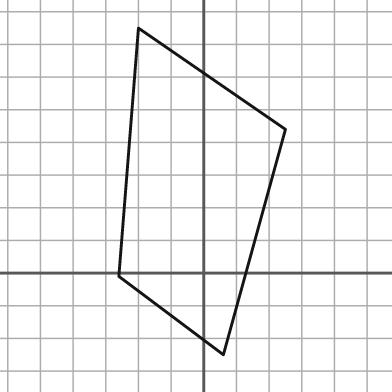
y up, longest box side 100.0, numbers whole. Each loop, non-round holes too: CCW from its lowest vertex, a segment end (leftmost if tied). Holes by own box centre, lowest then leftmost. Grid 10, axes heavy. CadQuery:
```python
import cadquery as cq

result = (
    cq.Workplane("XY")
    .moveTo(6.0, -25.0)
    .lineTo(25.0, 44.0)
    .lineTo(-20.0, 75.0)
    .lineTo(-26.0, -1.0)
    .close()
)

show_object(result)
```